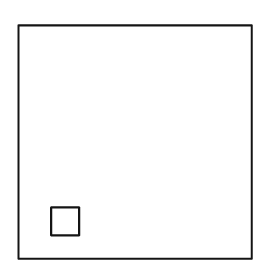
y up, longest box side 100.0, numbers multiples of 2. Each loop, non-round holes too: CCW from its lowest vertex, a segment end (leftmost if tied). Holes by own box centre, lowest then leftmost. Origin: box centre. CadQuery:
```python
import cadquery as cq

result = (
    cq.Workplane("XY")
    .moveTo(-50.0, -50.0)
    .lineTo(50.0, -50.0)
    .lineTo(50.0, 50.0)
    .lineTo(-50.0, 50.0)
    .close()
    .moveTo(-36.0, -40.0)
    .lineTo(-24.0, -40.0)
    .lineTo(-24.0, -28.0)
    .lineTo(-36.0, -28.0)
    .close()
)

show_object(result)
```